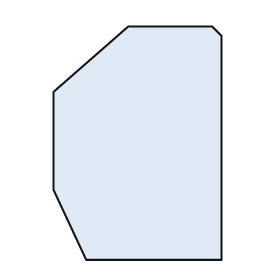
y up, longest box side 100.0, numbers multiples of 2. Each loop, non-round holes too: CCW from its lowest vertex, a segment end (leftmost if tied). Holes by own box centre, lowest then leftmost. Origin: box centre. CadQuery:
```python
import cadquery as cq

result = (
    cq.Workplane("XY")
    .moveTo(-22.0, -50.0)
    .lineTo(36.0, -50.0)
    .lineTo(36.0, 46.0)
    .lineTo(32.0, 50.0)
    .lineTo(-4.0, 50.0)
    .lineTo(-36.0, 22.0)
    .lineTo(-36.0, -20.0)
    .close()
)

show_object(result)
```